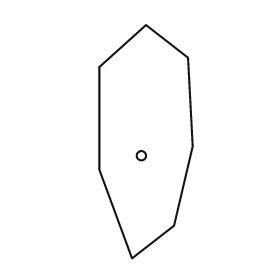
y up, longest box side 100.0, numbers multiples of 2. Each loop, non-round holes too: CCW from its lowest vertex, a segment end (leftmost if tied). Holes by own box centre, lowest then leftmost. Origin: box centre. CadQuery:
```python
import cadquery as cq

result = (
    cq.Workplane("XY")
    .moveTo(-6.0, -50.0)
    .lineTo(12.0, -36.0)
    .lineTo(20.0, -2.0)
    .lineTo(18.0, 36.0)
    .lineTo(0.0, 50.0)
    .lineTo(-20.0, 32.0)
    .lineTo(-20.0, -12.0)
    .close()
    .moveTo(-2.0, -6.0)
    .circle(2.0)
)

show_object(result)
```